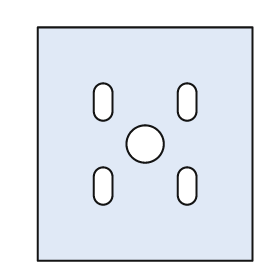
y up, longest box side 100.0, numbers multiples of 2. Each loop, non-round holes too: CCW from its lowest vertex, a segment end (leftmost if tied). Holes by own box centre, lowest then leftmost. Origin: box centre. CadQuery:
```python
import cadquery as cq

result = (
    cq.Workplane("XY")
    .moveTo(-46.0, -50.0)
    .lineTo(46.0, -50.0)
    .lineTo(46.0, 50.0)
    .lineTo(-46.0, 50.0)
    .close()
    .moveTo(-22.0, -22.0)
    .threePointArc((-18.0, -26.0), (-14.0, -22.0))
    .lineTo(-14.0, -14.0)
    .threePointArc((-18.0, -10.0), (-22.0, -14.0))
    .close()
    .moveTo(14.0, -22.0)
    .threePointArc((18.0, -26.0), (22.0, -22.0))
    .lineTo(22.0, -14.0)
    .threePointArc((18.0, -10.0), (14.0, -14.0))
    .close()
    .moveTo(0.0, 0.0)
    .circle(8.0)
    .moveTo(-22.0, 14.0)
    .threePointArc((-18.0, 10.0), (-14.0, 14.0))
    .lineTo(-14.0, 22.0)
    .threePointArc((-18.0, 26.0), (-22.0, 22.0))
    .close()
    .moveTo(14.0, 14.0)
    .threePointArc((18.0, 10.0), (22.0, 14.0))
    .lineTo(22.0, 22.0)
    .threePointArc((18.0, 26.0), (14.0, 22.0))
    .close()
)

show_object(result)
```